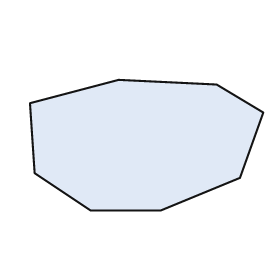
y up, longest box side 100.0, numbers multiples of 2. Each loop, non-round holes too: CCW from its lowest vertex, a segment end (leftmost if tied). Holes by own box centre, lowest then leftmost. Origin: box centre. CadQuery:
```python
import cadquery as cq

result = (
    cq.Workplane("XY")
    .moveTo(-24.0, -28.0)
    .lineTo(6.0, -28.0)
    .lineTo(40.0, -14.0)
    .lineTo(50.0, 14.0)
    .lineTo(30.0, 26.0)
    .lineTo(-12.0, 28.0)
    .lineTo(-50.0, 18.0)
    .lineTo(-48.0, -12.0)
    .close()
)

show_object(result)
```